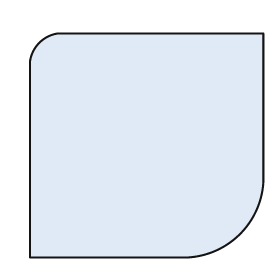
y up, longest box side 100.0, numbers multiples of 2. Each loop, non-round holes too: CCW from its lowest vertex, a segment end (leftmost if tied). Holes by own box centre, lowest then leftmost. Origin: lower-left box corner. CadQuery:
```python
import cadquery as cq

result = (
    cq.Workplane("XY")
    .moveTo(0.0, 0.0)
    .lineTo(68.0, 0.0)
    .threePointArc((90.0, 10.0), (100.0, 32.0))
    .lineTo(100.0, 96.0)
    .lineTo(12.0, 96.0)
    .threePointArc((4.0, 92.0), (0.0, 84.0))
    .close()
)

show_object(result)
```